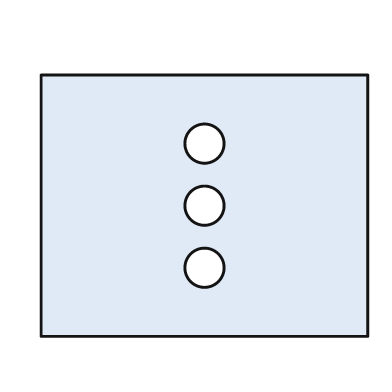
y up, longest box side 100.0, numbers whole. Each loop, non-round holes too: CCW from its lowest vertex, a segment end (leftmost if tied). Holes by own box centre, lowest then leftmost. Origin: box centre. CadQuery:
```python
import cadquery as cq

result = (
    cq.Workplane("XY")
    .moveTo(-50.0, -40.0)
    .lineTo(50.0, -40.0)
    .lineTo(50.0, 40.0)
    .lineTo(-50.0, 40.0)
    .close()
    .moveTo(0.0, -19.0)
    .circle(6.0)
    .moveTo(0.0, 0.0)
    .circle(6.0)
    .moveTo(0.0, 19.0)
    .circle(6.0)
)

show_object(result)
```